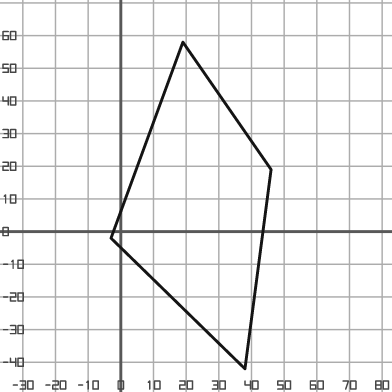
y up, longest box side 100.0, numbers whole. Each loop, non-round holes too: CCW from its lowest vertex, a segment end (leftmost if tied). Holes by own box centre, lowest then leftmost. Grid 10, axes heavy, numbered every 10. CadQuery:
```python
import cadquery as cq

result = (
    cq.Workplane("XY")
    .moveTo(38.0, -42.0)
    .lineTo(46.0, 19.0)
    .lineTo(19.0, 58.0)
    .lineTo(-3.0, -2.0)
    .close()
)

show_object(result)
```